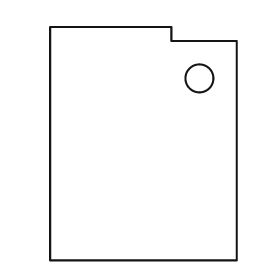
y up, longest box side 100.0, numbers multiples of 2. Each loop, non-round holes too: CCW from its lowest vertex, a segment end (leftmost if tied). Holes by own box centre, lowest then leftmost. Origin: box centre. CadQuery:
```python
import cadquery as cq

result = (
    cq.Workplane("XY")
    .moveTo(-40.0, -50.0)
    .lineTo(40.0, -50.0)
    .lineTo(40.0, 44.0)
    .lineTo(12.0, 44.0)
    .lineTo(12.0, 50.0)
    .lineTo(-40.0, 50.0)
    .close()
    .moveTo(24.0, 28.0)
    .circle(6.0)
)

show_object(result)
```